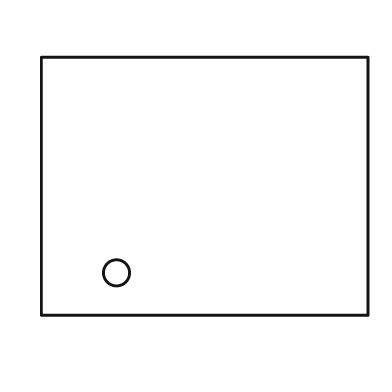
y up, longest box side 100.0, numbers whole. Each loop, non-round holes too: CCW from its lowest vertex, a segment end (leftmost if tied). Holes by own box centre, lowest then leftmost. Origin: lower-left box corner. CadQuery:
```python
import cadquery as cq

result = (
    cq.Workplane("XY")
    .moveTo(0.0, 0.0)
    .lineTo(100.0, 0.0)
    .lineTo(100.0, 79.0)
    .lineTo(0.0, 79.0)
    .close()
    .moveTo(23.0, 13.0)
    .circle(4.0)
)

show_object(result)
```